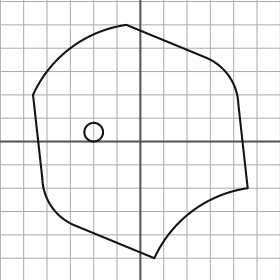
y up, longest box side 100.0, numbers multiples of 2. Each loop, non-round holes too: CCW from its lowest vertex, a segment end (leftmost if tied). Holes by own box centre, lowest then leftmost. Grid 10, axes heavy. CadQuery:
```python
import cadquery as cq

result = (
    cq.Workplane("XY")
    .moveTo(6.0, -50.0)
    .threePointArc((22.0, -30.0), (46.0, -20.0))
    .lineTo(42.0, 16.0)
    .threePointArc((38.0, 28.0), (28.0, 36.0))
    .lineTo(-6.0, 50.0)
    .threePointArc((-30.0, 40.0), (-46.0, 20.0))
    .lineTo(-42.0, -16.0)
    .threePointArc((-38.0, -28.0), (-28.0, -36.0))
    .close()
    .moveTo(-20.0, 4.0)
    .circle(4.0)
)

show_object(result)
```